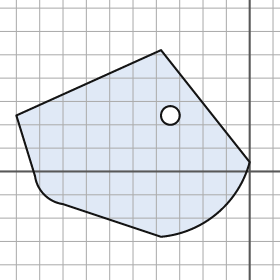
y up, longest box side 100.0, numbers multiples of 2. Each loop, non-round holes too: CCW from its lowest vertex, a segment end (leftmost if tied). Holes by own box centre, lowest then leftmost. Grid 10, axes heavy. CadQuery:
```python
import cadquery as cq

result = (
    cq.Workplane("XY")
    .moveTo(-38.0, -28.0)
    .threePointArc((-14.0, -18.0), (0.0, 4.0))
    .lineTo(-38.0, 52.0)
    .lineTo(-100.0, 24.0)
    .lineTo(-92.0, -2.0)
    .threePointArc((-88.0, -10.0), (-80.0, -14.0))
    .close()
    .moveTo(-34.0, 24.0)
    .circle(4.0)
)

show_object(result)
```